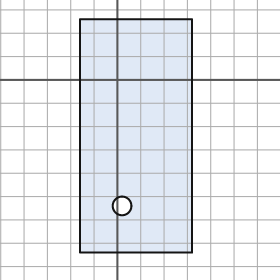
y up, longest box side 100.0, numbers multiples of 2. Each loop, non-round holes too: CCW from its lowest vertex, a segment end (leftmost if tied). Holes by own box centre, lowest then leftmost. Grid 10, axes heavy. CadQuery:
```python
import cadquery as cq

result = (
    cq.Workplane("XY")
    .moveTo(-16.0, -74.0)
    .lineTo(32.0, -74.0)
    .lineTo(32.0, 26.0)
    .lineTo(-16.0, 26.0)
    .close()
    .moveTo(2.0, -54.0)
    .circle(4.0)
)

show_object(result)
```